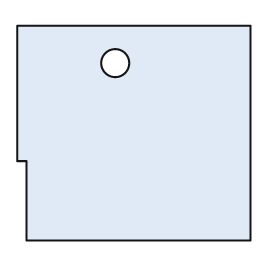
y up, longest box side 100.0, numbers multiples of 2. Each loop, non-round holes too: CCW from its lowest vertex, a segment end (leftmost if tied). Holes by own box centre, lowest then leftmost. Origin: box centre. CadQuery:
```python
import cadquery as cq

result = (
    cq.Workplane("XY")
    .moveTo(-46.0, -46.0)
    .lineTo(50.0, -46.0)
    .lineTo(50.0, 46.0)
    .lineTo(-50.0, 46.0)
    .lineTo(-50.0, -12.0)
    .lineTo(-46.0, -12.0)
    .close()
    .moveTo(-8.0, 30.0)
    .circle(6.0)
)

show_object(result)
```